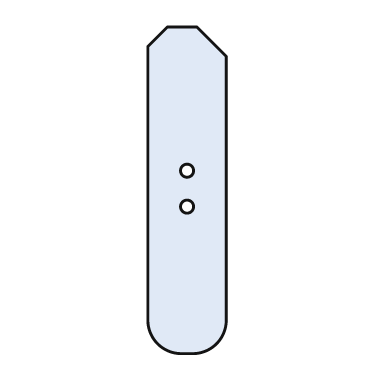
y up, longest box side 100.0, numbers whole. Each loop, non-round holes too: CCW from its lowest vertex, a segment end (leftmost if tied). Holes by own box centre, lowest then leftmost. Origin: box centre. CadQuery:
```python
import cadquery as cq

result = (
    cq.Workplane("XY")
    .moveTo(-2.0, -50.0)
    .lineTo(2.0, -50.0)
    .threePointArc((9.0, -47.0), (12.0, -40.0))
    .lineTo(12.0, 41.0)
    .lineTo(3.0, 50.0)
    .lineTo(-6.0, 50.0)
    .lineTo(-12.0, 44.0)
    .lineTo(-12.0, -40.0)
    .threePointArc((-9.0, -47.0), (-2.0, -50.0))
    .close()
    .moveTo(0.0, -5.0)
    .circle(2.0)
    .moveTo(0.0, 6.0)
    .circle(2.0)
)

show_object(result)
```